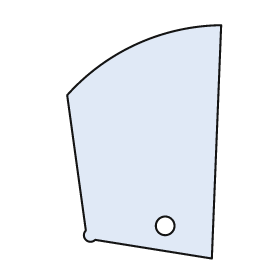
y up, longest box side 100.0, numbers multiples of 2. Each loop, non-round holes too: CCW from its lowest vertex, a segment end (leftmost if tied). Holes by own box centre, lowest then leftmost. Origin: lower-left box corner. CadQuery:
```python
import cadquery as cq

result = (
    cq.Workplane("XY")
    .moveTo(62.0, 0.0)
    .lineTo(66.0, 100.0)
    .threePointArc((30.0, 92.0), (0.0, 70.0))
    .lineTo(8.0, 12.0)
    .threePointArc((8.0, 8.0), (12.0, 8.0))
    .close()
    .moveTo(42.0, 14.0)
    .circle(4.0)
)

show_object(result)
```